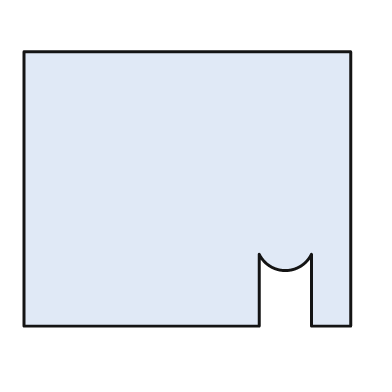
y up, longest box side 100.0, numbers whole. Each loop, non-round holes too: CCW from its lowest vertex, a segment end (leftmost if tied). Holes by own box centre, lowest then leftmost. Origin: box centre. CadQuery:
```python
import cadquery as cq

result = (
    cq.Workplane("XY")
    .moveTo(-50.0, -42.0)
    .lineTo(22.0, -42.0)
    .lineTo(22.0, -20.0)
    .threePointArc((30.0, -25.0), (38.0, -20.0))
    .lineTo(38.0, -42.0)
    .lineTo(50.0, -42.0)
    .lineTo(50.0, 42.0)
    .lineTo(-50.0, 42.0)
    .close()
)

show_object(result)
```